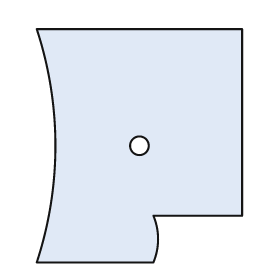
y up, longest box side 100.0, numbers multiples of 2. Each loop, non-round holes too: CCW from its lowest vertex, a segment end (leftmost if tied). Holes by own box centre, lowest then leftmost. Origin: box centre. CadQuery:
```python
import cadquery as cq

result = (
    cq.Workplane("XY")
    .moveTo(-44.0, -50.0)
    .lineTo(6.0, -50.0)
    .threePointArc((8.0, -40.0), (6.0, -30.0))
    .lineTo(44.0, -30.0)
    .lineTo(44.0, 50.0)
    .lineTo(-44.0, 50.0)
    .threePointArc((-36.0, 0.0), (-44.0, -50.0))
    .close()
    .moveTo(0.0, 0.0)
    .circle(4.0)
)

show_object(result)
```